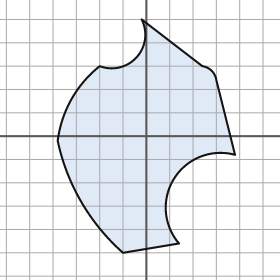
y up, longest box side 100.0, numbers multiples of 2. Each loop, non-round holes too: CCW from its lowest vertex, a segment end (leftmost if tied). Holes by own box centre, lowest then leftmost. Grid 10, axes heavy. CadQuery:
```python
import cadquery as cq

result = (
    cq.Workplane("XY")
    .moveTo(-10.0, -50.0)
    .lineTo(14.0, -46.0)
    .threePointArc((12.0, -18.0), (38.0, -8.0))
    .lineTo(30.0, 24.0)
    .threePointArc((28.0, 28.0), (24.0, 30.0))
    .lineTo(-2.0, 50.0)
    .threePointArc((-4.0, 34.0), (-20.0, 30.0))
    .threePointArc((-32.0, 16.0), (-38.0, -2.0))
    .threePointArc((-28.0, -28.0), (-10.0, -50.0))
    .close()
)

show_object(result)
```